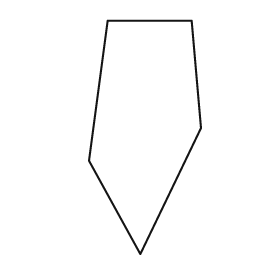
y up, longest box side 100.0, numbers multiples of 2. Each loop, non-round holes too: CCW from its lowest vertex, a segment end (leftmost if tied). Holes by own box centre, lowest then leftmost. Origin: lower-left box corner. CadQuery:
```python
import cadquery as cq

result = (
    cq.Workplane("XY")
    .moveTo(22.0, 0.0)
    .lineTo(48.0, 54.0)
    .lineTo(44.0, 100.0)
    .lineTo(8.0, 100.0)
    .lineTo(0.0, 40.0)
    .close()
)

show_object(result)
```